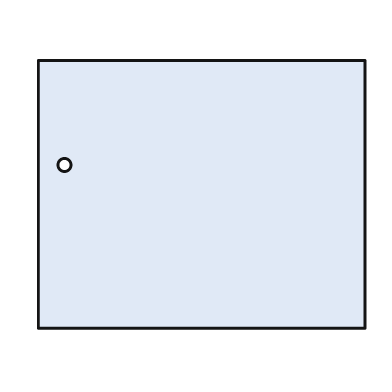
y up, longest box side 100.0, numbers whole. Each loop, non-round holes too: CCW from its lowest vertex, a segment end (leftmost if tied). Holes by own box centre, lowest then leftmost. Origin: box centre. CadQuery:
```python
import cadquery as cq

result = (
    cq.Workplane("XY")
    .moveTo(-50.0, -41.0)
    .lineTo(50.0, -41.0)
    .lineTo(50.0, 41.0)
    .lineTo(-50.0, 41.0)
    .close()
    .moveTo(-42.0, 9.0)
    .circle(2.0)
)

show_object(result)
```